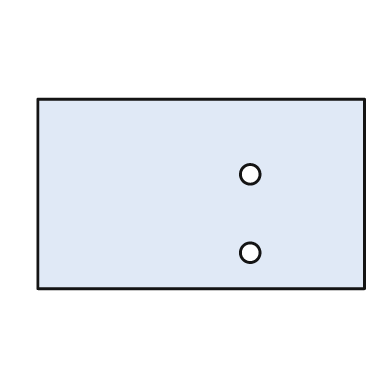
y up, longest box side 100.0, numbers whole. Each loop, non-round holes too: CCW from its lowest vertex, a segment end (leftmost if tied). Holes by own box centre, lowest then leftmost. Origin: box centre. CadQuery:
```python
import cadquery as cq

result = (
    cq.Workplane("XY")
    .moveTo(-50.0, -29.0)
    .lineTo(50.0, -29.0)
    .lineTo(50.0, 29.0)
    .lineTo(-50.0, 29.0)
    .close()
    .moveTo(15.0, -18.0)
    .circle(3.0)
    .moveTo(15.0, 6.0)
    .circle(3.0)
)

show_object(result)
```